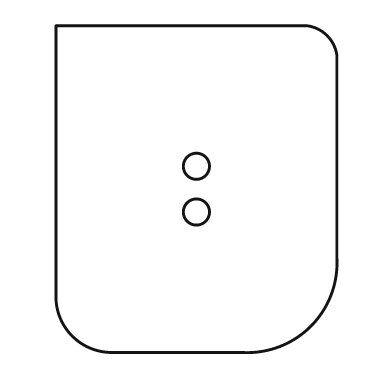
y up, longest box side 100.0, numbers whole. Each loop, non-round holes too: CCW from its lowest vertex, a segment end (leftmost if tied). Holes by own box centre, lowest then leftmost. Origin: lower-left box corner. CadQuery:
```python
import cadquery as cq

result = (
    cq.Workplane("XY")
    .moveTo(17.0, 0.0)
    .lineTo(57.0, 0.0)
    .threePointArc((78.0, 8.0), (86.0, 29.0))
    .lineTo(86.0, 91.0)
    .threePointArc((83.0, 97.0), (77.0, 100.0))
    .lineTo(0.0, 100.0)
    .lineTo(0.0, 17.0)
    .threePointArc((5.0, 5.0), (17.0, 0.0))
    .close()
    .moveTo(43.0, 43.0)
    .circle(4.0)
    .moveTo(43.0, 57.0)
    .circle(4.0)
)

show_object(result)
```